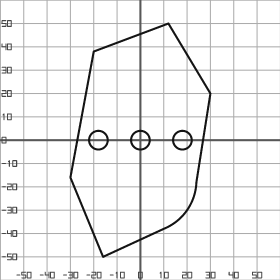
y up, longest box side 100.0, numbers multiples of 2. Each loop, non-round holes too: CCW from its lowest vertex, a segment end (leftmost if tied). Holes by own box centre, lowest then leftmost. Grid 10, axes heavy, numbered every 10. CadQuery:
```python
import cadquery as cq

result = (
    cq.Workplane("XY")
    .moveTo(-16.0, -50.0)
    .lineTo(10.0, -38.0)
    .threePointArc((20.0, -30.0), (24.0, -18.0))
    .lineTo(30.0, 20.0)
    .lineTo(12.0, 50.0)
    .lineTo(-20.0, 38.0)
    .lineTo(-30.0, -16.0)
    .close()
    .moveTo(-18.0, 0.0)
    .circle(4.0)
    .moveTo(0.0, 0.0)
    .circle(4.0)
    .moveTo(18.0, 0.0)
    .circle(4.0)
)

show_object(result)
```